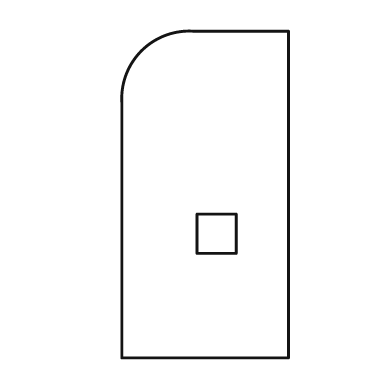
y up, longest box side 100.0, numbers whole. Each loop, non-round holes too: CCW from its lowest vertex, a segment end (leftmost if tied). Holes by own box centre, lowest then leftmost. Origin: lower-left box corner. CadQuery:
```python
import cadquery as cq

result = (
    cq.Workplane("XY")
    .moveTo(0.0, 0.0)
    .lineTo(51.0, 0.0)
    .lineTo(51.0, 100.0)
    .lineTo(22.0, 100.0)
    .threePointArc((6.0, 94.0), (0.0, 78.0))
    .close()
    .moveTo(23.0, 32.0)
    .lineTo(35.0, 32.0)
    .lineTo(35.0, 44.0)
    .lineTo(23.0, 44.0)
    .close()
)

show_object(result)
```